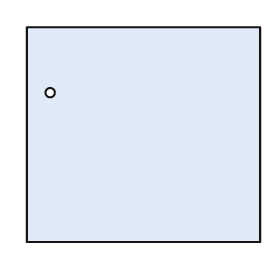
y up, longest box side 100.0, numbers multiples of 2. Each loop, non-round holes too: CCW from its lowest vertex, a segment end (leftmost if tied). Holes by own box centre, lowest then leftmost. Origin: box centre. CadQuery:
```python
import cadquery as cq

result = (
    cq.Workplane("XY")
    .moveTo(-50.0, -46.0)
    .lineTo(50.0, -46.0)
    .lineTo(50.0, 46.0)
    .lineTo(-50.0, 46.0)
    .close()
    .moveTo(-40.0, 18.0)
    .circle(2.0)
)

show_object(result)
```